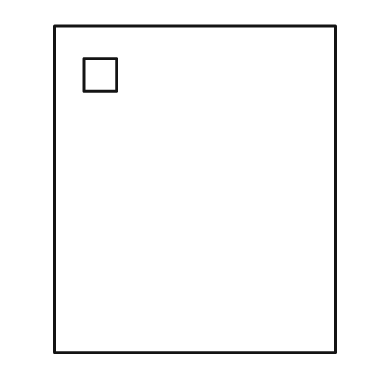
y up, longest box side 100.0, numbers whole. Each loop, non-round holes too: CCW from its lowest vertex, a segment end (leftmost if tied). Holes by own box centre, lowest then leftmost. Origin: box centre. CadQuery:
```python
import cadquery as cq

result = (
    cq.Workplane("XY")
    .moveTo(-43.0, -50.0)
    .lineTo(43.0, -50.0)
    .lineTo(43.0, 50.0)
    .lineTo(-43.0, 50.0)
    .close()
    .moveTo(-34.0, 30.0)
    .lineTo(-24.0, 30.0)
    .lineTo(-24.0, 40.0)
    .lineTo(-34.0, 40.0)
    .close()
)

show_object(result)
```